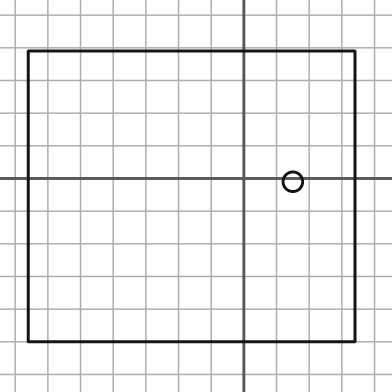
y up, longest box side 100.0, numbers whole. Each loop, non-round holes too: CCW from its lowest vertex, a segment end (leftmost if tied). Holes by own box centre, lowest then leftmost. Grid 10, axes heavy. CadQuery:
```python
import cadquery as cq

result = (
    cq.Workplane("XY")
    .moveTo(-66.0, -50.0)
    .lineTo(34.0, -50.0)
    .lineTo(34.0, 39.0)
    .lineTo(-66.0, 39.0)
    .close()
    .moveTo(15.0, -1.0)
    .circle(3.0)
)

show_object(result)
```